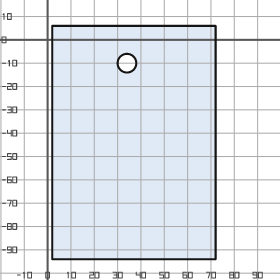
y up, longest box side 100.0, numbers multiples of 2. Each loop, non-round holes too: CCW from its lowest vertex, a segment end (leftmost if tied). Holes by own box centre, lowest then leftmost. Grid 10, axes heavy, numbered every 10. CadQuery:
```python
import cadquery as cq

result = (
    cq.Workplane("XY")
    .moveTo(2.0, -94.0)
    .lineTo(72.0, -94.0)
    .lineTo(72.0, 6.0)
    .lineTo(2.0, 6.0)
    .close()
    .moveTo(34.0, -10.0)
    .circle(4.0)
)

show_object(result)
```